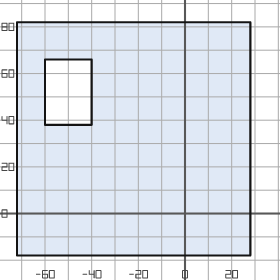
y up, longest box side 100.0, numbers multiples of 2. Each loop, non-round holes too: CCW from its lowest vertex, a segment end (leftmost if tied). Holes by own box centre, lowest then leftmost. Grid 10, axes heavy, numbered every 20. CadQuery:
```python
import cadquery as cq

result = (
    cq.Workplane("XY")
    .moveTo(-72.0, -18.0)
    .lineTo(28.0, -18.0)
    .lineTo(28.0, 82.0)
    .lineTo(-72.0, 82.0)
    .close()
    .moveTo(-60.0, 38.0)
    .lineTo(-40.0, 38.0)
    .lineTo(-40.0, 66.0)
    .lineTo(-60.0, 66.0)
    .close()
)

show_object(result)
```